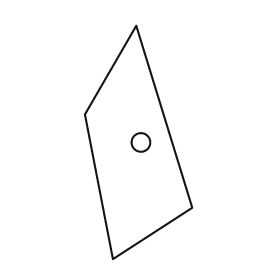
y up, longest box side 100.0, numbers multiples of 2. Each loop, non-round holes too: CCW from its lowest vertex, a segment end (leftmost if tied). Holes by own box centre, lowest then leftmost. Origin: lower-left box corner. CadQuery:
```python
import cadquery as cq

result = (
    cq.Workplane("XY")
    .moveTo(12.0, 0.0)
    .lineTo(46.0, 22.0)
    .lineTo(22.0, 100.0)
    .lineTo(0.0, 62.0)
    .close()
    .moveTo(24.0, 50.0)
    .circle(4.0)
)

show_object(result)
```